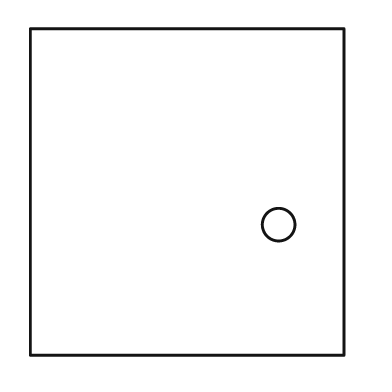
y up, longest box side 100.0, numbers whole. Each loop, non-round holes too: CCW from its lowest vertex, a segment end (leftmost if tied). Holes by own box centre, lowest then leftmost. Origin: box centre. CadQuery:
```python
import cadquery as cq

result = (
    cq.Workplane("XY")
    .moveTo(-48.0, -50.0)
    .lineTo(48.0, -50.0)
    .lineTo(48.0, 50.0)
    .lineTo(-48.0, 50.0)
    .close()
    .moveTo(28.0, -10.0)
    .circle(5.0)
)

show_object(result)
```